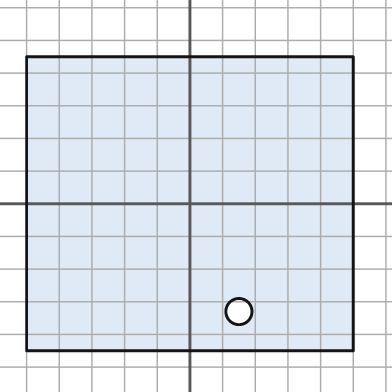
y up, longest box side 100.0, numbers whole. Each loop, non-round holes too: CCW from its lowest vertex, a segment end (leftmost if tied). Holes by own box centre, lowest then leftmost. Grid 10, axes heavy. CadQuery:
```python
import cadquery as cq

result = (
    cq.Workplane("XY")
    .moveTo(-50.0, -45.0)
    .lineTo(50.0, -45.0)
    .lineTo(50.0, 45.0)
    .lineTo(-50.0, 45.0)
    .close()
    .moveTo(15.0, -33.0)
    .circle(4.0)
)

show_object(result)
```